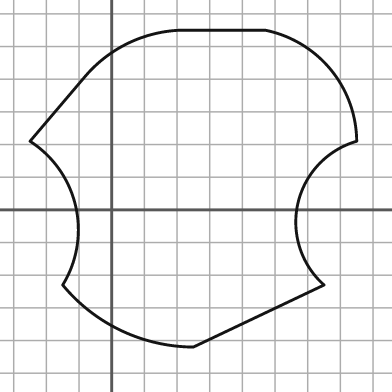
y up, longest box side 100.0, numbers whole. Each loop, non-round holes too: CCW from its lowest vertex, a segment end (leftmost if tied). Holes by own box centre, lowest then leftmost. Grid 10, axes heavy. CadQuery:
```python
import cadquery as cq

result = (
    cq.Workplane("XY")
    .moveTo(25.0, -42.0)
    .lineTo(65.0, -23.0)
    .threePointArc((57.0, 2.0), (75.0, 21.0))
    .threePointArc((67.0, 43.0), (47.0, 55.0))
    .lineTo(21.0, 55.0)
    .threePointArc((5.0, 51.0), (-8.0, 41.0))
    .lineTo(-25.0, 21.0)
    .threePointArc((-11.0, 1.0), (-15.0, -23.0))
    .threePointArc((3.0, -37.0), (25.0, -42.0))
    .close()
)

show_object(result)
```